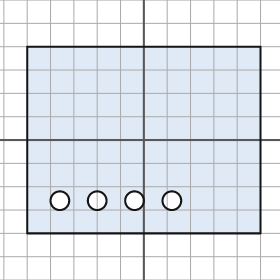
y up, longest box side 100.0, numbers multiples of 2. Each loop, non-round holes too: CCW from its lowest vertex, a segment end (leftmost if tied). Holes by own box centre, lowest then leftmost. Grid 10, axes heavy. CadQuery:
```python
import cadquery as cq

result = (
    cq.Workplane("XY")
    .moveTo(-50.0, -40.0)
    .lineTo(50.0, -40.0)
    .lineTo(50.0, 40.0)
    .lineTo(-50.0, 40.0)
    .close()
    .moveTo(-36.0, -26.0)
    .circle(4.0)
    .moveTo(-20.0, -26.0)
    .circle(4.0)
    .moveTo(-4.0, -26.0)
    .circle(4.0)
    .moveTo(12.0, -26.0)
    .circle(4.0)
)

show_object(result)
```